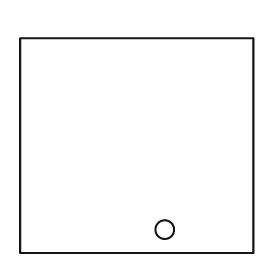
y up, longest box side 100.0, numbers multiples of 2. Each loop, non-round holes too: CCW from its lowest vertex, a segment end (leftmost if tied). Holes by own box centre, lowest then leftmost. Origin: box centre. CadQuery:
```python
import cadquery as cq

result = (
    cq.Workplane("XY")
    .moveTo(-50.0, -46.0)
    .lineTo(50.0, -46.0)
    .lineTo(50.0, 46.0)
    .lineTo(-50.0, 46.0)
    .close()
    .moveTo(12.0, -36.0)
    .circle(4.0)
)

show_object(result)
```